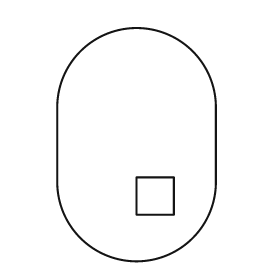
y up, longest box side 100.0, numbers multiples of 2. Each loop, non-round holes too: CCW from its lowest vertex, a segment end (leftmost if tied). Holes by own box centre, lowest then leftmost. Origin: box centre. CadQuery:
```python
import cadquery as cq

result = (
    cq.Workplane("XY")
    .moveTo(-34.0, -16.0)
    .threePointArc((0.0, -50.0), (34.0, -16.0))
    .lineTo(34.0, 16.0)
    .threePointArc((0.0, 50.0), (-34.0, 16.0))
    .close()
    .moveTo(0.0, -30.0)
    .lineTo(16.0, -30.0)
    .lineTo(16.0, -14.0)
    .lineTo(0.0, -14.0)
    .close()
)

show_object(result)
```